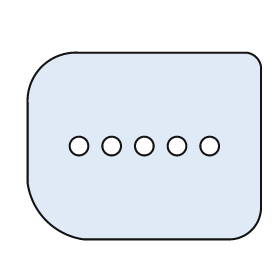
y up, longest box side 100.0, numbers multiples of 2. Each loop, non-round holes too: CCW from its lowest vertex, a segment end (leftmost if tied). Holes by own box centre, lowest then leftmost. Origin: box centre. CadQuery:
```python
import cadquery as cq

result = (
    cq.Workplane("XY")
    .moveTo(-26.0, -40.0)
    .lineTo(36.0, -40.0)
    .threePointArc((46.0, -36.0), (50.0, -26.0))
    .lineTo(50.0, 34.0)
    .threePointArc((48.0, 38.0), (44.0, 40.0))
    .lineTo(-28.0, 40.0)
    .threePointArc((-44.0, 34.0), (-50.0, 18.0))
    .lineTo(-50.0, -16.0)
    .threePointArc((-42.0, -32.0), (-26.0, -40.0))
    .close()
    .moveTo(-28.0, 0.0)
    .circle(4.0)
    .moveTo(-14.0, 0.0)
    .circle(4.0)
    .moveTo(0.0, 0.0)
    .circle(4.0)
    .moveTo(14.0, 0.0)
    .circle(4.0)
    .moveTo(28.0, 0.0)
    .circle(4.0)
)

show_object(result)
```